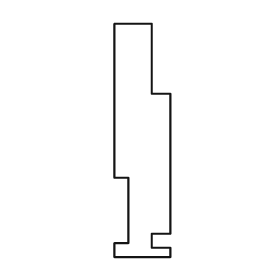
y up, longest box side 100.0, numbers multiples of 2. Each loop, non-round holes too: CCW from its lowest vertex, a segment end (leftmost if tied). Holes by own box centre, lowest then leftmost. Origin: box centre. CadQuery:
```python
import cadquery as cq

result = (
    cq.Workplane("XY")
    .moveTo(-12.0, -50.0)
    .lineTo(12.0, -50.0)
    .lineTo(12.0, -46.0)
    .lineTo(4.0, -46.0)
    .lineTo(4.0, -40.0)
    .lineTo(12.0, -40.0)
    .lineTo(12.0, 20.0)
    .lineTo(4.0, 20.0)
    .lineTo(4.0, 50.0)
    .lineTo(-12.0, 50.0)
    .lineTo(-12.0, -16.0)
    .lineTo(-6.0, -16.0)
    .lineTo(-6.0, -44.0)
    .lineTo(-12.0, -44.0)
    .close()
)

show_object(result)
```